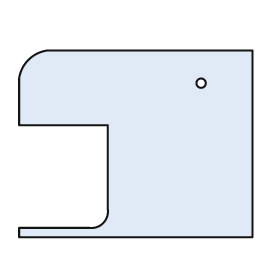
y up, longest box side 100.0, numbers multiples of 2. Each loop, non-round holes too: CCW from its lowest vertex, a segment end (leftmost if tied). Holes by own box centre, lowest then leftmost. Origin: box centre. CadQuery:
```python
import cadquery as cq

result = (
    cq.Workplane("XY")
    .moveTo(-50.0, -40.0)
    .lineTo(50.0, -40.0)
    .lineTo(50.0, 40.0)
    .lineTo(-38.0, 40.0)
    .threePointArc((-46.0, 36.0), (-50.0, 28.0))
    .lineTo(-50.0, 8.0)
    .lineTo(-12.0, 8.0)
    .lineTo(-12.0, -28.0)
    .threePointArc((-14.0, -34.0), (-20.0, -36.0))
    .lineTo(-50.0, -36.0)
    .close()
    .moveTo(28.0, 26.0)
    .circle(2.0)
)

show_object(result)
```